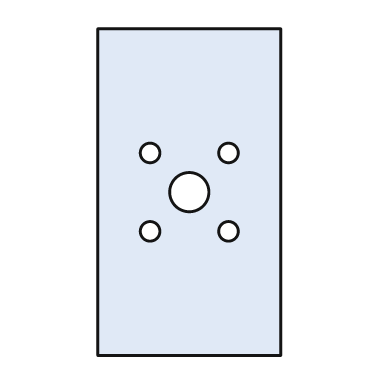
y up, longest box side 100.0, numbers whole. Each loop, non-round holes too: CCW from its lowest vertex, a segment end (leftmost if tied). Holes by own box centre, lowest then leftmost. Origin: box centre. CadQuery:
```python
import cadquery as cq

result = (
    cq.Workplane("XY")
    .moveTo(-28.0, -50.0)
    .lineTo(28.0, -50.0)
    .lineTo(28.0, 50.0)
    .lineTo(-28.0, 50.0)
    .close()
    .moveTo(-12.0, -12.0)
    .circle(3.0)
    .moveTo(12.0, -12.0)
    .circle(3.0)
    .moveTo(0.0, 0.0)
    .circle(6.0)
    .moveTo(-12.0, 12.0)
    .circle(3.0)
    .moveTo(12.0, 12.0)
    .circle(3.0)
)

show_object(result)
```